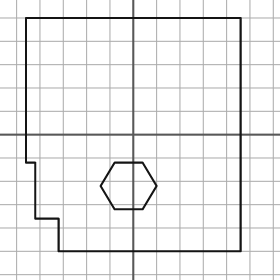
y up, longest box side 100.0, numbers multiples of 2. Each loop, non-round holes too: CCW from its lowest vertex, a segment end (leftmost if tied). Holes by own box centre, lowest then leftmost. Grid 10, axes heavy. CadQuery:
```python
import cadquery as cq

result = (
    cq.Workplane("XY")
    .moveTo(-32.0, -50.0)
    .lineTo(46.0, -50.0)
    .lineTo(46.0, 50.0)
    .lineTo(-46.0, 50.0)
    .lineTo(-46.0, -12.0)
    .lineTo(-42.0, -12.0)
    .lineTo(-42.0, -36.0)
    .lineTo(-32.0, -36.0)
    .close()
    .moveTo(-8.0, -32.0)
    .lineTo(4.0, -32.0)
    .lineTo(10.0, -22.0)
    .lineTo(4.0, -12.0)
    .lineTo(-8.0, -12.0)
    .lineTo(-14.0, -22.0)
    .close()
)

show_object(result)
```